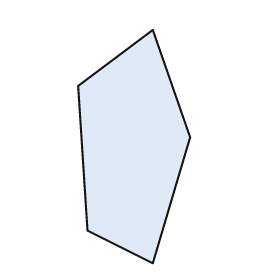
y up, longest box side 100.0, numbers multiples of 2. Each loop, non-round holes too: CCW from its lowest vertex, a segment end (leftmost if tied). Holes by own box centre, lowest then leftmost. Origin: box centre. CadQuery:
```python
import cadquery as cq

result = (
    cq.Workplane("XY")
    .moveTo(8.0, -50.0)
    .lineTo(24.0, 4.0)
    .lineTo(8.0, 50.0)
    .lineTo(-24.0, 26.0)
    .lineTo(-20.0, -36.0)
    .close()
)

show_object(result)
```